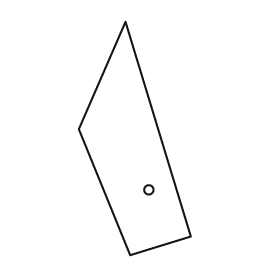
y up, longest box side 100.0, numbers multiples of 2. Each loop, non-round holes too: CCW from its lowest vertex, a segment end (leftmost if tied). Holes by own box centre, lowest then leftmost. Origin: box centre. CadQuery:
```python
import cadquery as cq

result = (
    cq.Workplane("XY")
    .moveTo(-2.0, -50.0)
    .lineTo(24.0, -42.0)
    .lineTo(-4.0, 50.0)
    .lineTo(-24.0, 4.0)
    .close()
    .moveTo(6.0, -22.0)
    .circle(2.0)
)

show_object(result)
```